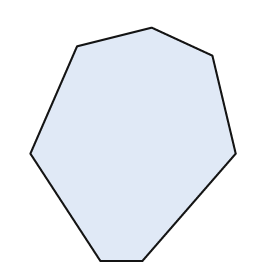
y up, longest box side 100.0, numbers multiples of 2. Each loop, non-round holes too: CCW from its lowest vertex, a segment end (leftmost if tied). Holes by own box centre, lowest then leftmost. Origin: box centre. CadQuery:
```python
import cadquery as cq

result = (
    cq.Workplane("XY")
    .moveTo(-14.0, -50.0)
    .lineTo(4.0, -50.0)
    .lineTo(44.0, -4.0)
    .lineTo(34.0, 38.0)
    .lineTo(8.0, 50.0)
    .lineTo(-24.0, 42.0)
    .lineTo(-44.0, -4.0)
    .close()
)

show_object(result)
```